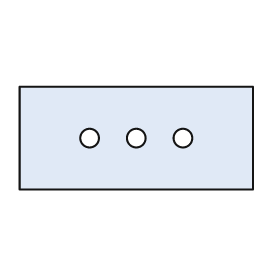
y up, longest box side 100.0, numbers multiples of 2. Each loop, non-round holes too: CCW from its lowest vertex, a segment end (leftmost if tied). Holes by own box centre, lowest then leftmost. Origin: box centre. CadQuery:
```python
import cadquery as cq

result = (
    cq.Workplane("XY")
    .moveTo(-50.0, -22.0)
    .lineTo(50.0, -22.0)
    .lineTo(50.0, 22.0)
    .lineTo(-50.0, 22.0)
    .close()
    .moveTo(-20.0, 0.0)
    .circle(4.0)
    .moveTo(0.0, 0.0)
    .circle(4.0)
    .moveTo(20.0, 0.0)
    .circle(4.0)
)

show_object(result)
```